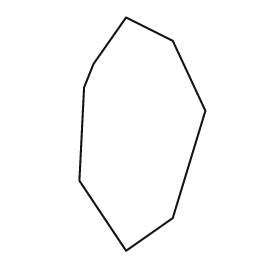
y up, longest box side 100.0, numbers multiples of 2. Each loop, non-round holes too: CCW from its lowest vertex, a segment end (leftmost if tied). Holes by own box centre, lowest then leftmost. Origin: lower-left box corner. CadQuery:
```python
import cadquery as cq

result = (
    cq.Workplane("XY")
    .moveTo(20.0, 0.0)
    .lineTo(40.0, 14.0)
    .lineTo(54.0, 60.0)
    .lineTo(40.0, 90.0)
    .lineTo(20.0, 100.0)
    .lineTo(6.0, 80.0)
    .lineTo(2.0, 70.0)
    .lineTo(0.0, 30.0)
    .close()
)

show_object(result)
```